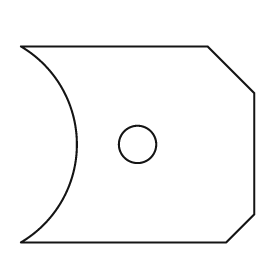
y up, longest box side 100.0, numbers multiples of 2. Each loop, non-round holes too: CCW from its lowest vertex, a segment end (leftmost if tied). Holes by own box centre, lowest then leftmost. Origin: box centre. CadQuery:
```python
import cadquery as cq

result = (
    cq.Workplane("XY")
    .moveTo(-50.0, -42.0)
    .lineTo(38.0, -42.0)
    .lineTo(50.0, -30.0)
    .lineTo(50.0, 22.0)
    .lineTo(30.0, 42.0)
    .lineTo(-50.0, 42.0)
    .threePointArc((-26.0, 0.0), (-50.0, -42.0))
    .close()
    .moveTo(0.0, 0.0)
    .circle(8.0)
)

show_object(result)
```